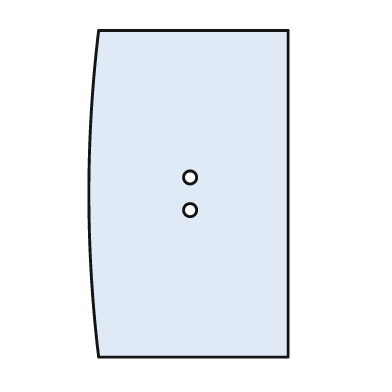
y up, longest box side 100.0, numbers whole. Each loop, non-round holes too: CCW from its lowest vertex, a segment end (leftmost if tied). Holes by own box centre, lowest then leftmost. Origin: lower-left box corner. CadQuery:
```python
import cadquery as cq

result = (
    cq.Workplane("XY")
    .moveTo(3.0, 0.0)
    .lineTo(61.0, 0.0)
    .lineTo(61.0, 100.0)
    .lineTo(3.0, 100.0)
    .threePointArc((0.0, 50.0), (3.0, 0.0))
    .close()
    .moveTo(31.0, 45.0)
    .circle(2.0)
    .moveTo(31.0, 55.0)
    .circle(2.0)
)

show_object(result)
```